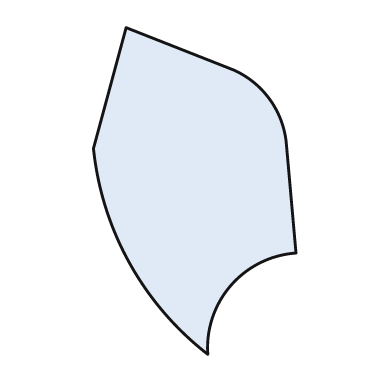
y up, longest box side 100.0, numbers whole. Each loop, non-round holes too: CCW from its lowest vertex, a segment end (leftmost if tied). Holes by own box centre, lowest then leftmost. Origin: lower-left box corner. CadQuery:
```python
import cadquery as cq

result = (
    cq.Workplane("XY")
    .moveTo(35.0, 0.0)
    .threePointArc((42.0, 21.0), (62.0, 31.0))
    .lineTo(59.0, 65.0)
    .threePointArc((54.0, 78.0), (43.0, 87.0))
    .lineTo(10.0, 100.0)
    .lineTo(0.0, 63.0)
    .threePointArc((11.0, 28.0), (35.0, 0.0))
    .close()
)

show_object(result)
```